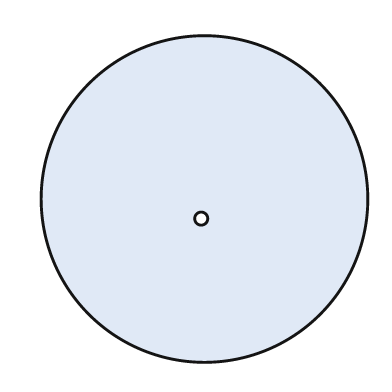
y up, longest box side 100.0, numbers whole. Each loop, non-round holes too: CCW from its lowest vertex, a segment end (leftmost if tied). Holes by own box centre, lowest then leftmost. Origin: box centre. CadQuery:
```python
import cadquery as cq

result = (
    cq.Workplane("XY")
    .moveTo(0.0, 0.0)
    .circle(50.0)
    .moveTo(-1.0, -6.0)
    .circle(2.0)
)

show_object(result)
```